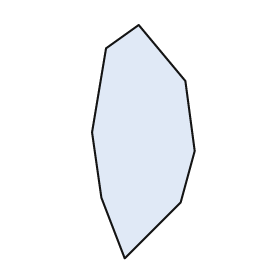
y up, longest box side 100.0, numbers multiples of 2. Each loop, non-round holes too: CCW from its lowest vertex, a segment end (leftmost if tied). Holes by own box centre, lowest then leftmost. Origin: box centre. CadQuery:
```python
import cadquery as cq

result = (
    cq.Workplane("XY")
    .moveTo(-8.0, -50.0)
    .lineTo(16.0, -26.0)
    .lineTo(22.0, -4.0)
    .lineTo(18.0, 26.0)
    .lineTo(-2.0, 50.0)
    .lineTo(-16.0, 40.0)
    .lineTo(-22.0, 4.0)
    .lineTo(-18.0, -24.0)
    .close()
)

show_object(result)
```